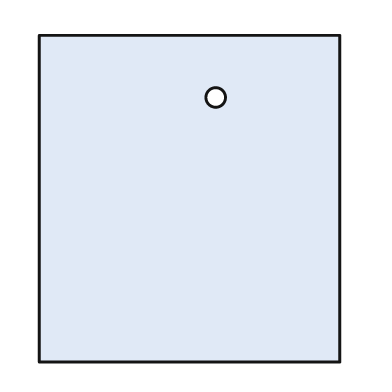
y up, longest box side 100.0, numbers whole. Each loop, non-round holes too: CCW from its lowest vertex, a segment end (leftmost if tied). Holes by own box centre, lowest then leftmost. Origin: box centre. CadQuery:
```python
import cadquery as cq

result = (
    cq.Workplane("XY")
    .moveTo(-46.0, -50.0)
    .lineTo(46.0, -50.0)
    .lineTo(46.0, 50.0)
    .lineTo(-46.0, 50.0)
    .close()
    .moveTo(8.0, 31.0)
    .circle(3.0)
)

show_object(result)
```